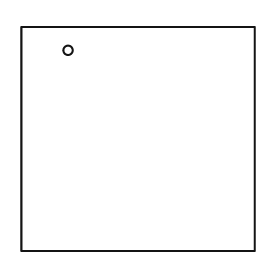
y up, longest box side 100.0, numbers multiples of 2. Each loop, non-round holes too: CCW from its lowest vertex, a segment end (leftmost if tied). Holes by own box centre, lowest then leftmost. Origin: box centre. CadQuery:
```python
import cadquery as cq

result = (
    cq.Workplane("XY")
    .moveTo(-50.0, -48.0)
    .lineTo(50.0, -48.0)
    .lineTo(50.0, 48.0)
    .lineTo(-50.0, 48.0)
    .close()
    .moveTo(-30.0, 38.0)
    .circle(2.0)
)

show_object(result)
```